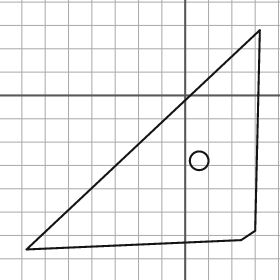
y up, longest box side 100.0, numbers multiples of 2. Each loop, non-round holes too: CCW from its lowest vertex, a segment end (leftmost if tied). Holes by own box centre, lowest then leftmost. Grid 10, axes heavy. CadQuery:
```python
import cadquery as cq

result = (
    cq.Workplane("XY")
    .moveTo(-68.0, -66.0)
    .lineTo(24.0, -62.0)
    .lineTo(30.0, -58.0)
    .lineTo(32.0, 28.0)
    .close()
    .moveTo(6.0, -28.0)
    .circle(4.0)
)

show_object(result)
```